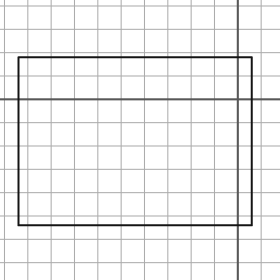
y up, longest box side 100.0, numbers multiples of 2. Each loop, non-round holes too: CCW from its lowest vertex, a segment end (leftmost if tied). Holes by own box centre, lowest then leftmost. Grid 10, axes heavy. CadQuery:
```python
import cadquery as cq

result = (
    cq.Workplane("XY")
    .moveTo(-94.0, -54.0)
    .lineTo(6.0, -54.0)
    .lineTo(6.0, 18.0)
    .lineTo(-94.0, 18.0)
    .close()
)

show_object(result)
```